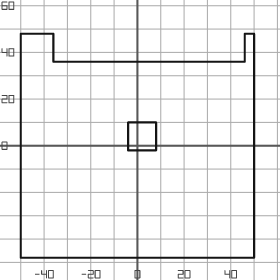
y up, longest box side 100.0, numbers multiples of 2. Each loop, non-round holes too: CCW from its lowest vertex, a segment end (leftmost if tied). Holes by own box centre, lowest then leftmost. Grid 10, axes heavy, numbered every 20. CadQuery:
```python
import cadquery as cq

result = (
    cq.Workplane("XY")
    .moveTo(-50.0, -48.0)
    .lineTo(50.0, -48.0)
    .lineTo(50.0, 48.0)
    .lineTo(46.0, 48.0)
    .lineTo(46.0, 36.0)
    .lineTo(-36.0, 36.0)
    .lineTo(-36.0, 48.0)
    .lineTo(-50.0, 48.0)
    .close()
    .moveTo(-4.0, -2.0)
    .lineTo(8.0, -2.0)
    .lineTo(8.0, 10.0)
    .lineTo(-4.0, 10.0)
    .close()
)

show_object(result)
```